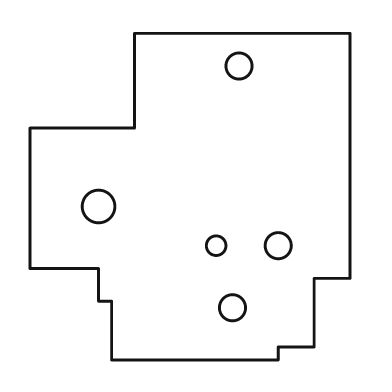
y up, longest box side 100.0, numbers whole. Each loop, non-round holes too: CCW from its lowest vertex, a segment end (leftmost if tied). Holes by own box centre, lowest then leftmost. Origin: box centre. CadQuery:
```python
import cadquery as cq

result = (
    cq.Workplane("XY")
    .moveTo(-24.0, -50.0)
    .lineTo(27.0, -50.0)
    .lineTo(27.0, -46.0)
    .lineTo(38.0, -46.0)
    .lineTo(38.0, -25.0)
    .lineTo(49.0, -25.0)
    .lineTo(49.0, 50.0)
    .lineTo(-17.0, 50.0)
    .lineTo(-17.0, 21.0)
    .lineTo(-49.0, 21.0)
    .lineTo(-49.0, -22.0)
    .lineTo(-28.0, -22.0)
    .lineTo(-28.0, -32.0)
    .lineTo(-24.0, -32.0)
    .close()
    .moveTo(13.0, -34.0)
    .circle(4.0)
    .moveTo(8.0, -15.0)
    .circle(3.0)
    .moveTo(27.0, -15.0)
    .circle(4.0)
    .moveTo(-28.0, -3.0)
    .circle(5.0)
    .moveTo(15.0, 40.0)
    .circle(4.0)
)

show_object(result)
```